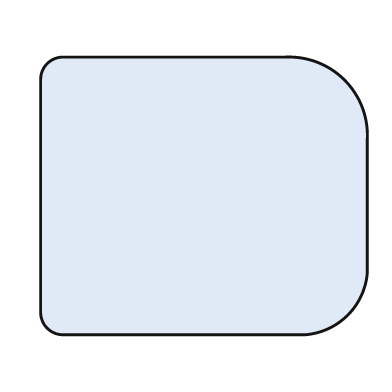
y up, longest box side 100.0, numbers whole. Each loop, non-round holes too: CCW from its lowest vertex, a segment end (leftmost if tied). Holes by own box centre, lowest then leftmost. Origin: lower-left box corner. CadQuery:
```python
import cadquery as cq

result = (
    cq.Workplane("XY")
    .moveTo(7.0, 0.0)
    .lineTo(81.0, 0.0)
    .threePointArc((94.0, 6.0), (100.0, 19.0))
    .lineTo(100.0, 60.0)
    .threePointArc((93.0, 78.0), (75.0, 85.0))
    .lineTo(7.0, 85.0)
    .threePointArc((2.0, 83.0), (0.0, 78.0))
    .lineTo(0.0, 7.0)
    .threePointArc((2.0, 2.0), (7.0, 0.0))
    .close()
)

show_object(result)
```